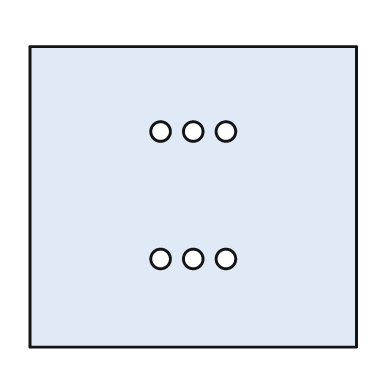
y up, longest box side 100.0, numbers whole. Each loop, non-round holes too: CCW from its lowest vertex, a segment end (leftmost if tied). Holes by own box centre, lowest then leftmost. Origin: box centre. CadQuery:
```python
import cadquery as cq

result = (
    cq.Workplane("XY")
    .moveTo(-50.0, -46.0)
    .lineTo(50.0, -46.0)
    .lineTo(50.0, 46.0)
    .lineTo(-50.0, 46.0)
    .close()
    .moveTo(-10.0, -19.0)
    .circle(3.0)
    .moveTo(0.0, -19.0)
    .circle(3.0)
    .moveTo(10.0, -19.0)
    .circle(3.0)
    .moveTo(-10.0, 20.0)
    .circle(3.0)
    .moveTo(0.0, 20.0)
    .circle(3.0)
    .moveTo(10.0, 20.0)
    .circle(3.0)
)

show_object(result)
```